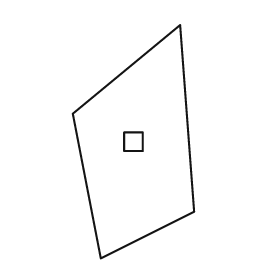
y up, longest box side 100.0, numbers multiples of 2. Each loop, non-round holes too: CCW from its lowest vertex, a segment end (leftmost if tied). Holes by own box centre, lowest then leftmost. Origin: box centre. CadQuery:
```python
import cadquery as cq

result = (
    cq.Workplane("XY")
    .moveTo(-14.0, -50.0)
    .lineTo(26.0, -30.0)
    .lineTo(20.0, 50.0)
    .lineTo(-26.0, 12.0)
    .close()
    .moveTo(-4.0, -4.0)
    .lineTo(4.0, -4.0)
    .lineTo(4.0, 4.0)
    .lineTo(-4.0, 4.0)
    .close()
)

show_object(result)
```